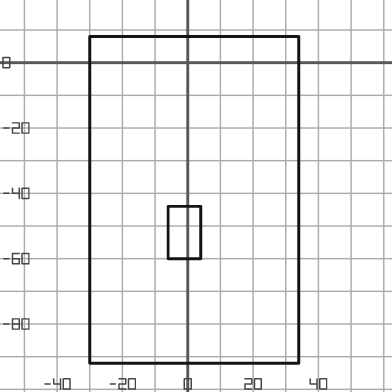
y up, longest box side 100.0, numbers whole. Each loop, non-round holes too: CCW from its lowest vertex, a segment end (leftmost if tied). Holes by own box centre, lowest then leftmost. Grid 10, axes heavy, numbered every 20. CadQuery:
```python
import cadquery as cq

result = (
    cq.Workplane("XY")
    .moveTo(-30.0, -92.0)
    .lineTo(34.0, -92.0)
    .lineTo(34.0, 8.0)
    .lineTo(-30.0, 8.0)
    .close()
    .moveTo(-6.0, -60.0)
    .lineTo(4.0, -60.0)
    .lineTo(4.0, -44.0)
    .lineTo(-6.0, -44.0)
    .close()
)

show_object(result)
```